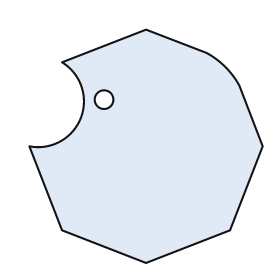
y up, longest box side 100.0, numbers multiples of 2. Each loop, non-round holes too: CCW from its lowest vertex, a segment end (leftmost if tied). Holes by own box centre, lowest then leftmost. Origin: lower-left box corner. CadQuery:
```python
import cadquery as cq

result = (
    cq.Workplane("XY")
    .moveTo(50.0, 0.0)
    .lineTo(86.0, 14.0)
    .lineTo(100.0, 50.0)
    .lineTo(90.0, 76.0)
    .threePointArc((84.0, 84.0), (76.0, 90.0))
    .lineTo(50.0, 100.0)
    .lineTo(14.0, 86.0)
    .threePointArc((22.0, 62.0), (0.0, 50.0))
    .lineTo(14.0, 14.0)
    .close()
    .moveTo(32.0, 70.0)
    .circle(4.0)
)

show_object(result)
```